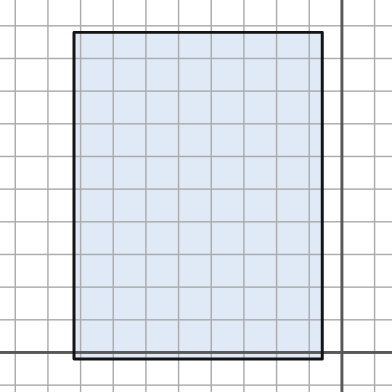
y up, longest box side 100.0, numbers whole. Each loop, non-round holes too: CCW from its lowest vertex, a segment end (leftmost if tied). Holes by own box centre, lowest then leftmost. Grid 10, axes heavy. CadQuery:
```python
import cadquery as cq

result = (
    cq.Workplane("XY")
    .moveTo(-82.0, -2.0)
    .lineTo(-6.0, -2.0)
    .lineTo(-6.0, 98.0)
    .lineTo(-82.0, 98.0)
    .close()
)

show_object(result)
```